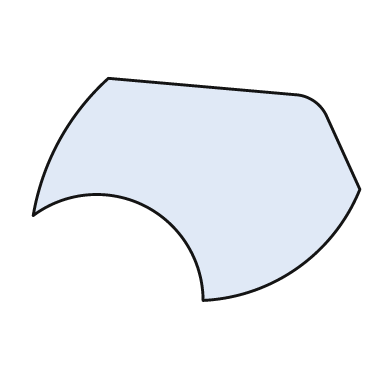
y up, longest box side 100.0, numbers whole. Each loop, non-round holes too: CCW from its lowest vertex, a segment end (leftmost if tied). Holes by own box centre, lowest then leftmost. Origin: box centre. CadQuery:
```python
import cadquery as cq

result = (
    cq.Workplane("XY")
    .moveTo(2.0, -34.0)
    .threePointArc((31.0, -24.0), (50.0, 0.0))
    .lineTo(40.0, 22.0)
    .threePointArc((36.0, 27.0), (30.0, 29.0))
    .lineTo(-27.0, 34.0)
    .threePointArc((-42.0, 15.0), (-50.0, -8.0))
    .threePointArc((-16.0, -5.0), (2.0, -34.0))
    .close()
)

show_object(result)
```